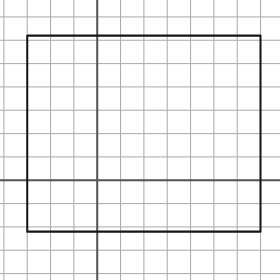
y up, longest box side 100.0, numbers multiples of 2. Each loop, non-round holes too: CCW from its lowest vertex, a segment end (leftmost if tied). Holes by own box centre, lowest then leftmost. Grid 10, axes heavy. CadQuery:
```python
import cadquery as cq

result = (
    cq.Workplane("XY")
    .moveTo(-30.0, -22.0)
    .lineTo(70.0, -22.0)
    .lineTo(70.0, 62.0)
    .lineTo(-30.0, 62.0)
    .close()
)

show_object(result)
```